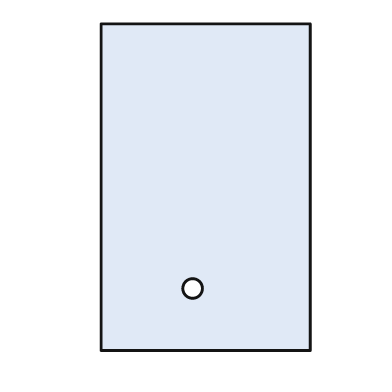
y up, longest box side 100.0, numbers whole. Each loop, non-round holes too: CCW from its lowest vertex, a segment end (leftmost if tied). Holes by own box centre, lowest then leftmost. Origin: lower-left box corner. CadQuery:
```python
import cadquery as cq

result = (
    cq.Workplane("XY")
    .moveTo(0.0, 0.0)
    .lineTo(64.0, 0.0)
    .lineTo(64.0, 100.0)
    .lineTo(0.0, 100.0)
    .close()
    .moveTo(28.0, 19.0)
    .circle(3.0)
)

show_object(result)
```